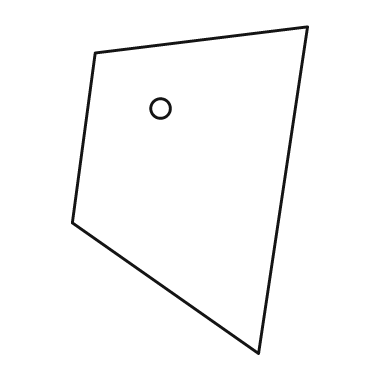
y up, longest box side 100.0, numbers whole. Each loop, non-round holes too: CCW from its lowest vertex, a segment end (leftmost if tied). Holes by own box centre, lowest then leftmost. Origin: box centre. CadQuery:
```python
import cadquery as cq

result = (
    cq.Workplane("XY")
    .moveTo(21.0, -50.0)
    .lineTo(36.0, 50.0)
    .lineTo(-29.0, 42.0)
    .lineTo(-36.0, -10.0)
    .close()
    .moveTo(-9.0, 25.0)
    .circle(3.0)
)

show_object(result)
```